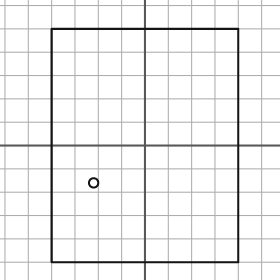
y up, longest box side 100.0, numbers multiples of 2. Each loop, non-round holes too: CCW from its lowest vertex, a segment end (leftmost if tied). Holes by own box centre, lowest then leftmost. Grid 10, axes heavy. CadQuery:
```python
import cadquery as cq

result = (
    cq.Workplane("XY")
    .moveTo(-40.0, -50.0)
    .lineTo(40.0, -50.0)
    .lineTo(40.0, 50.0)
    .lineTo(-40.0, 50.0)
    .close()
    .moveTo(-22.0, -16.0)
    .circle(2.0)
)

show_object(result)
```